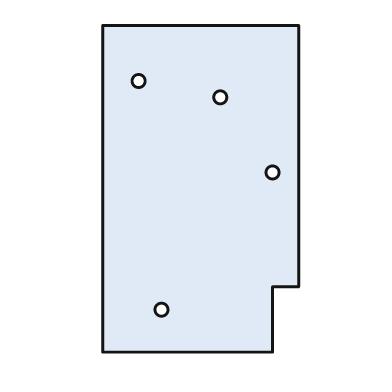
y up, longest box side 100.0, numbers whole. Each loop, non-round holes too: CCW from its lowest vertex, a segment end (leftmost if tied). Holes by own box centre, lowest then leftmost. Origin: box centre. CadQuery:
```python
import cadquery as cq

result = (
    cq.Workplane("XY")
    .moveTo(-30.0, -50.0)
    .lineTo(22.0, -50.0)
    .lineTo(22.0, -30.0)
    .lineTo(30.0, -30.0)
    .lineTo(30.0, 50.0)
    .lineTo(-30.0, 50.0)
    .close()
    .moveTo(-12.0, -37.0)
    .circle(2.0)
    .moveTo(22.0, 5.0)
    .circle(2.0)
    .moveTo(6.0, 28.0)
    .circle(2.0)
    .moveTo(-19.0, 33.0)
    .circle(2.0)
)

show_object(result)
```